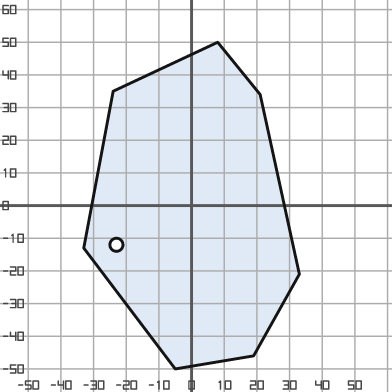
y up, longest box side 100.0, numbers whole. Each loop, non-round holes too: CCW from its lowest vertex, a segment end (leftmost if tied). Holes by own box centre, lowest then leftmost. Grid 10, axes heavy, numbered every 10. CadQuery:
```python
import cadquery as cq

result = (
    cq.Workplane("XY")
    .moveTo(-5.0, -50.0)
    .lineTo(19.0, -46.0)
    .lineTo(33.0, -21.0)
    .lineTo(21.0, 34.0)
    .lineTo(8.0, 50.0)
    .lineTo(-24.0, 35.0)
    .lineTo(-33.0, -13.0)
    .close()
    .moveTo(-23.0, -12.0)
    .circle(2.0)
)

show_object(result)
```